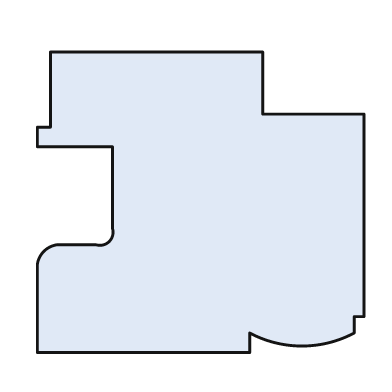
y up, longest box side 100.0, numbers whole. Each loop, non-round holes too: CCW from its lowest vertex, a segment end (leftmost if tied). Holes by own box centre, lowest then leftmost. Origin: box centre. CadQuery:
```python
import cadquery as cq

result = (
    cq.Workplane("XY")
    .moveTo(-50.0, -46.0)
    .lineTo(15.0, -46.0)
    .lineTo(15.0, -40.0)
    .threePointArc((31.0, -44.0), (47.0, -40.0))
    .lineTo(47.0, -35.0)
    .lineTo(50.0, -35.0)
    .lineTo(50.0, 27.0)
    .lineTo(19.0, 27.0)
    .lineTo(19.0, 46.0)
    .lineTo(-46.0, 46.0)
    .lineTo(-46.0, 23.0)
    .lineTo(-50.0, 23.0)
    .lineTo(-50.0, 17.0)
    .lineTo(-27.0, 17.0)
    .lineTo(-27.0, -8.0)
    .threePointArc((-28.0, -12.0), (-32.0, -13.0))
    .lineTo(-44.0, -13.0)
    .threePointArc((-48.0, -15.0), (-50.0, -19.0))
    .close()
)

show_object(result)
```